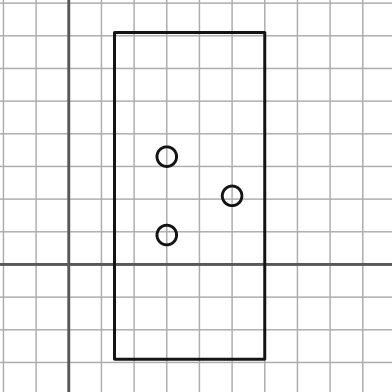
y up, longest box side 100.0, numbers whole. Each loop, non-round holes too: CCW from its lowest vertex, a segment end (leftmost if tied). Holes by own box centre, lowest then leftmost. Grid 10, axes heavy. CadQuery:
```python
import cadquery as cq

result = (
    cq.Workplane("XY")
    .moveTo(14.0, -29.0)
    .lineTo(60.0, -29.0)
    .lineTo(60.0, 71.0)
    .lineTo(14.0, 71.0)
    .close()
    .moveTo(30.0, 9.0)
    .circle(3.0)
    .moveTo(50.0, 21.0)
    .circle(3.0)
    .moveTo(30.0, 33.0)
    .circle(3.0)
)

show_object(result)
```